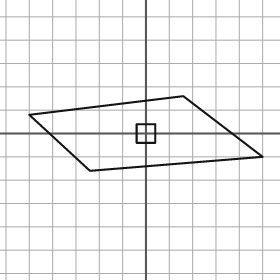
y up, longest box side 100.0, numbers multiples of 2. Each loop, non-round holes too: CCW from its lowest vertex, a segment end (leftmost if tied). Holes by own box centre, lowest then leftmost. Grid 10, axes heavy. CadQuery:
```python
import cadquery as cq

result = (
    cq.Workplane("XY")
    .moveTo(-24.0, -16.0)
    .lineTo(50.0, -10.0)
    .lineTo(16.0, 16.0)
    .lineTo(-50.0, 8.0)
    .close()
    .moveTo(-4.0, -4.0)
    .lineTo(4.0, -4.0)
    .lineTo(4.0, 4.0)
    .lineTo(-4.0, 4.0)
    .close()
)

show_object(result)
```